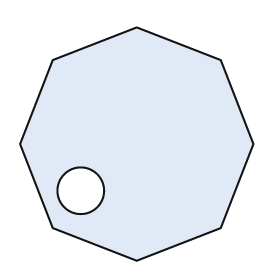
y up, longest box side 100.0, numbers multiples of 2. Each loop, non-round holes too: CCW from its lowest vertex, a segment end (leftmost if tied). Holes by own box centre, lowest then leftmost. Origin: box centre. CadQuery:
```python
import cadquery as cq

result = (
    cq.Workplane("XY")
    .moveTo(0.0, -50.0)
    .lineTo(36.0, -36.0)
    .lineTo(50.0, 0.0)
    .lineTo(36.0, 36.0)
    .lineTo(0.0, 50.0)
    .lineTo(-36.0, 36.0)
    .lineTo(-50.0, 0.0)
    .lineTo(-36.0, -36.0)
    .close()
    .moveTo(-24.0, -20.0)
    .circle(10.0)
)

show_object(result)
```